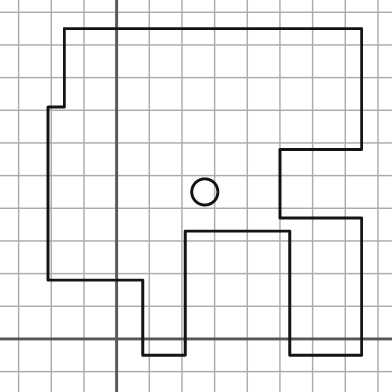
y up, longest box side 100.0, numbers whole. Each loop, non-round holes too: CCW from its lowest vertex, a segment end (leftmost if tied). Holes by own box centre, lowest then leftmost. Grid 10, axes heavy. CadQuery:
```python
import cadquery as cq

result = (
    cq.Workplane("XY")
    .moveTo(8.0, -5.0)
    .lineTo(21.0, -5.0)
    .lineTo(21.0, 33.0)
    .lineTo(53.0, 33.0)
    .lineTo(53.0, -5.0)
    .lineTo(75.0, -5.0)
    .lineTo(75.0, 37.0)
    .lineTo(50.0, 37.0)
    .lineTo(50.0, 58.0)
    .lineTo(75.0, 58.0)
    .lineTo(75.0, 95.0)
    .lineTo(-16.0, 95.0)
    .lineTo(-16.0, 71.0)
    .lineTo(-21.0, 71.0)
    .lineTo(-21.0, 18.0)
    .lineTo(8.0, 18.0)
    .close()
    .moveTo(27.0, 45.0)
    .circle(4.0)
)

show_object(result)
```